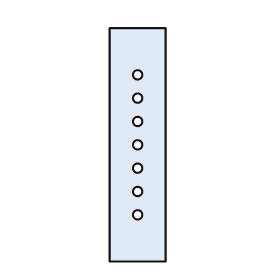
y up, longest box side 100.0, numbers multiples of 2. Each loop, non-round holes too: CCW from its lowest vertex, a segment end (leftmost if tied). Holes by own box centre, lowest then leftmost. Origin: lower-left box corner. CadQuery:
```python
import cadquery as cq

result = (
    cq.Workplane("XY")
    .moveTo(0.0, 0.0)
    .lineTo(24.0, 0.0)
    .lineTo(24.0, 100.0)
    .lineTo(0.0, 100.0)
    .close()
    .moveTo(12.0, 20.0)
    .circle(2.0)
    .moveTo(12.0, 30.0)
    .circle(2.0)
    .moveTo(12.0, 40.0)
    .circle(2.0)
    .moveTo(12.0, 50.0)
    .circle(2.0)
    .moveTo(12.0, 60.0)
    .circle(2.0)
    .moveTo(12.0, 70.0)
    .circle(2.0)
    .moveTo(12.0, 80.0)
    .circle(2.0)
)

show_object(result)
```